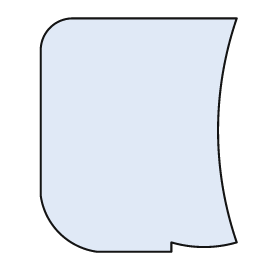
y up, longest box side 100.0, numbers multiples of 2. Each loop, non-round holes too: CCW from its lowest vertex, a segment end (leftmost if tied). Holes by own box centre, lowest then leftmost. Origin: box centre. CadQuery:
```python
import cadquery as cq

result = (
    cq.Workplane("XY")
    .moveTo(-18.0, -50.0)
    .lineTo(14.0, -50.0)
    .lineTo(14.0, -46.0)
    .threePointArc((28.0, -48.0), (42.0, -46.0))
    .threePointArc((34.0, 2.0), (42.0, 50.0))
    .lineTo(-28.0, 50.0)
    .threePointArc((-38.0, 46.0), (-42.0, 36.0))
    .lineTo(-42.0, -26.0)
    .threePointArc((-34.0, -42.0), (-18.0, -50.0))
    .close()
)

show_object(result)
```